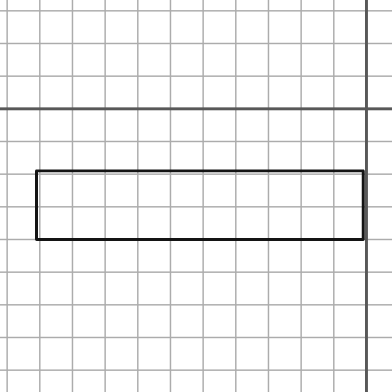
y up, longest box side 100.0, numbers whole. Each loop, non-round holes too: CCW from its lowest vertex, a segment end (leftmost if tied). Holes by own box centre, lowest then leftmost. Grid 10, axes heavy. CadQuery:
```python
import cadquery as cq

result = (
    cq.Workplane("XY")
    .moveTo(-101.0, -40.0)
    .lineTo(-1.0, -40.0)
    .lineTo(-1.0, -19.0)
    .lineTo(-101.0, -19.0)
    .close()
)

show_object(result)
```